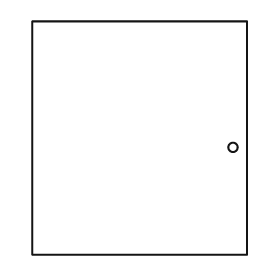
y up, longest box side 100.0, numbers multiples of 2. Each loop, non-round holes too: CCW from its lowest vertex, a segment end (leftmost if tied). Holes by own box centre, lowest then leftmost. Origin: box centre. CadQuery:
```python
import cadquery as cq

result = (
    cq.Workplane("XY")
    .moveTo(-46.0, -50.0)
    .lineTo(46.0, -50.0)
    .lineTo(46.0, 50.0)
    .lineTo(-46.0, 50.0)
    .close()
    .moveTo(40.0, -4.0)
    .circle(2.0)
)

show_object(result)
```